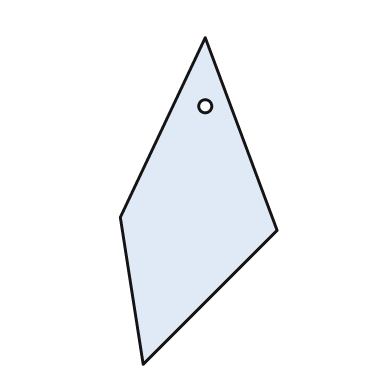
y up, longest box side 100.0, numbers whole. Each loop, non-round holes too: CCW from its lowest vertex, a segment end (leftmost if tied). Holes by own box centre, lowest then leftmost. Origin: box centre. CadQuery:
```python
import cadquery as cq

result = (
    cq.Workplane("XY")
    .moveTo(-17.0, -50.0)
    .lineTo(24.0, -9.0)
    .lineTo(2.0, 50.0)
    .lineTo(-24.0, -5.0)
    .close()
    .moveTo(2.0, 29.0)
    .circle(2.0)
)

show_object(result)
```